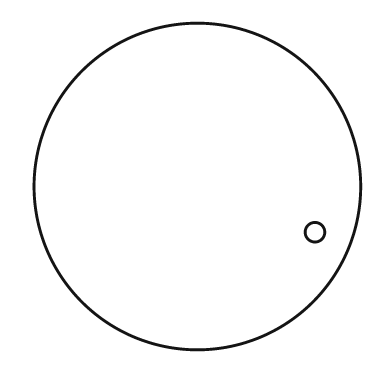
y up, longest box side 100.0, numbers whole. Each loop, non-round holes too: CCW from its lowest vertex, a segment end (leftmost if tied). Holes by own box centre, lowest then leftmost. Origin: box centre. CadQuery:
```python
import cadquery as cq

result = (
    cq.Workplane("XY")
    .moveTo(0.0, 0.0)
    .circle(50.0)
    .moveTo(36.0, -14.0)
    .circle(3.0)
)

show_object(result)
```